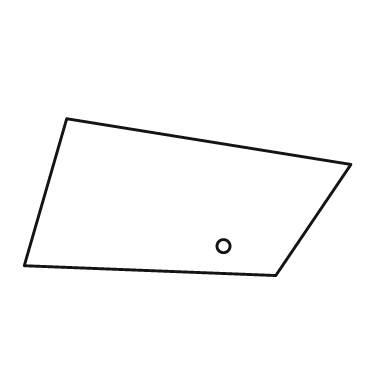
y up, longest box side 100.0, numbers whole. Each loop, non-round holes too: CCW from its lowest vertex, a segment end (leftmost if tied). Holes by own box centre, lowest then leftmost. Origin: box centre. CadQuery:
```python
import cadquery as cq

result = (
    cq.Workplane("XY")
    .moveTo(27.0, -24.0)
    .lineTo(50.0, 10.0)
    .lineTo(-37.0, 24.0)
    .lineTo(-50.0, -21.0)
    .close()
    .moveTo(11.0, -15.0)
    .circle(2.0)
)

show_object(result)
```